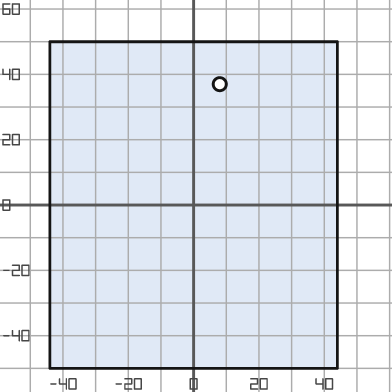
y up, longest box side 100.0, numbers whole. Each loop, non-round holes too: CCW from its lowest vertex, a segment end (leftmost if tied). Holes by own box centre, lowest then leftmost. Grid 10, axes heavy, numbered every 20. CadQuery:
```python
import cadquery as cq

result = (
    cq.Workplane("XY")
    .moveTo(-44.0, -50.0)
    .lineTo(44.0, -50.0)
    .lineTo(44.0, 50.0)
    .lineTo(-44.0, 50.0)
    .close()
    .moveTo(8.0, 37.0)
    .circle(2.0)
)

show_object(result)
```